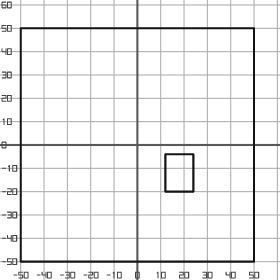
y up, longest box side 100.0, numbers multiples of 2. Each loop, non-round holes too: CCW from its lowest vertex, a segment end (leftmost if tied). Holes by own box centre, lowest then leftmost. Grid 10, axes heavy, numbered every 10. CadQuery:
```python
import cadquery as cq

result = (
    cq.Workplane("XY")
    .moveTo(-50.0, -50.0)
    .lineTo(50.0, -50.0)
    .lineTo(50.0, 50.0)
    .lineTo(-50.0, 50.0)
    .close()
    .moveTo(12.0, -20.0)
    .lineTo(24.0, -20.0)
    .lineTo(24.0, -4.0)
    .lineTo(12.0, -4.0)
    .close()
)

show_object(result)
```